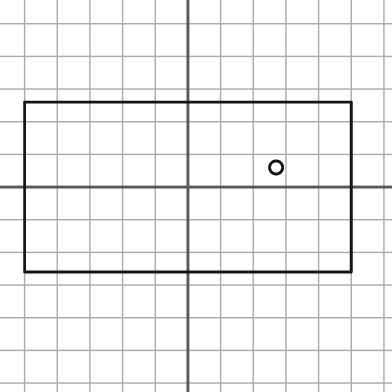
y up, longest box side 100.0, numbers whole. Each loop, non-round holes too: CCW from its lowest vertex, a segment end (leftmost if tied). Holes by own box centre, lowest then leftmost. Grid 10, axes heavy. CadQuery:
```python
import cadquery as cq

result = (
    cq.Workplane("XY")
    .moveTo(-50.0, -26.0)
    .lineTo(50.0, -26.0)
    .lineTo(50.0, 26.0)
    .lineTo(-50.0, 26.0)
    .close()
    .moveTo(27.0, 6.0)
    .circle(2.0)
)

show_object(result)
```